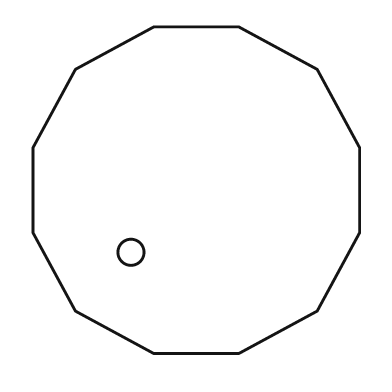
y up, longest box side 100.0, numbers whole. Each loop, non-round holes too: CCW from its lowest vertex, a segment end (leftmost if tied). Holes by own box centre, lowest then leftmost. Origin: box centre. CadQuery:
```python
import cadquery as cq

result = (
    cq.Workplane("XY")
    .moveTo(-13.0, -50.0)
    .lineTo(13.0, -50.0)
    .lineTo(37.0, -37.0)
    .lineTo(50.0, -13.0)
    .lineTo(50.0, 13.0)
    .lineTo(37.0, 37.0)
    .lineTo(13.0, 50.0)
    .lineTo(-13.0, 50.0)
    .lineTo(-37.0, 37.0)
    .lineTo(-50.0, 13.0)
    .lineTo(-50.0, -13.0)
    .lineTo(-37.0, -37.0)
    .close()
    .moveTo(-20.0, -19.0)
    .circle(4.0)
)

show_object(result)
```